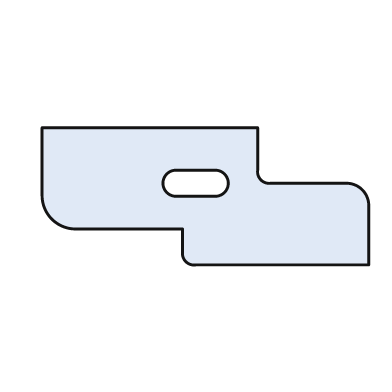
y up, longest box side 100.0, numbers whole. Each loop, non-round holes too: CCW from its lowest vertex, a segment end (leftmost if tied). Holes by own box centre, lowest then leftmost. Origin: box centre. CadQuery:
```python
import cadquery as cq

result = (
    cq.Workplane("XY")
    .moveTo(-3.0, -21.0)
    .lineTo(50.0, -21.0)
    .lineTo(50.0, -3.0)
    .threePointArc((48.0, 2.0), (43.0, 4.0))
    .lineTo(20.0, 4.0)
    .threePointArc((17.0, 5.0), (16.0, 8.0))
    .lineTo(16.0, 21.0)
    .lineTo(-50.0, 21.0)
    .lineTo(-50.0, 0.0)
    .threePointArc((-47.0, -7.0), (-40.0, -10.0))
    .lineTo(-7.0, -10.0)
    .lineTo(-7.0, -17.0)
    .threePointArc((-6.0, -20.0), (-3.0, -21.0))
    .close()
    .moveTo(-9.0, 0.0)
    .lineTo(3.0, 0.0)
    .threePointArc((7.0, 4.0), (3.0, 8.0))
    .lineTo(-9.0, 8.0)
    .threePointArc((-13.0, 4.0), (-9.0, 0.0))
    .close()
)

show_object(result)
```